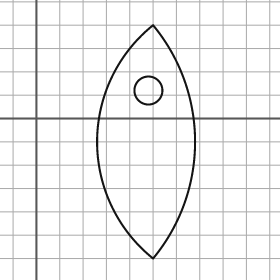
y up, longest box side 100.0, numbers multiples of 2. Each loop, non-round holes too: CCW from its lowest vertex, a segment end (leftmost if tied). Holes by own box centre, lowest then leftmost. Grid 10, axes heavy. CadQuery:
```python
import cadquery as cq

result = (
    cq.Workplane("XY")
    .moveTo(50.0, -60.0)
    .threePointArc((68.0, -10.0), (50.0, 40.0))
    .threePointArc((26.0, -10.0), (50.0, -60.0))
    .close()
    .moveTo(48.0, 12.0)
    .circle(6.0)
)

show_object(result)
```